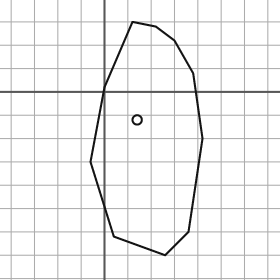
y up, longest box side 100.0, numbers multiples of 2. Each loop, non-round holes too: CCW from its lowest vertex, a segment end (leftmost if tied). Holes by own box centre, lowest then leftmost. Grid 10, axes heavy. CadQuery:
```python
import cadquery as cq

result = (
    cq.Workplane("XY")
    .moveTo(26.0, -70.0)
    .lineTo(36.0, -60.0)
    .lineTo(42.0, -20.0)
    .lineTo(38.0, 8.0)
    .lineTo(30.0, 22.0)
    .lineTo(22.0, 28.0)
    .lineTo(12.0, 30.0)
    .lineTo(0.0, 2.0)
    .lineTo(-6.0, -30.0)
    .lineTo(4.0, -62.0)
    .close()
    .moveTo(14.0, -12.0)
    .circle(2.0)
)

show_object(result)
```